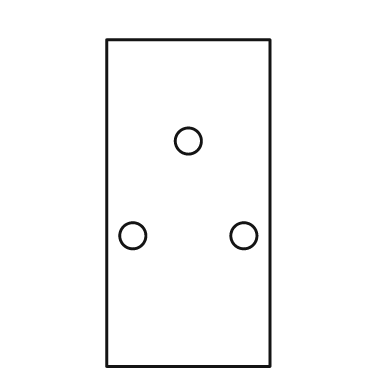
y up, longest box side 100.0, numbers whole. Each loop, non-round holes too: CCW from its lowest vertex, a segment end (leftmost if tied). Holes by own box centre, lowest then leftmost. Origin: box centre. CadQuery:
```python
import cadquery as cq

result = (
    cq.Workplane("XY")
    .moveTo(-25.0, -50.0)
    .lineTo(25.0, -50.0)
    .lineTo(25.0, 50.0)
    .lineTo(-25.0, 50.0)
    .close()
    .moveTo(-17.0, -10.0)
    .circle(4.0)
    .moveTo(17.0, -10.0)
    .circle(4.0)
    .moveTo(0.0, 19.0)
    .circle(4.0)
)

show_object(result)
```